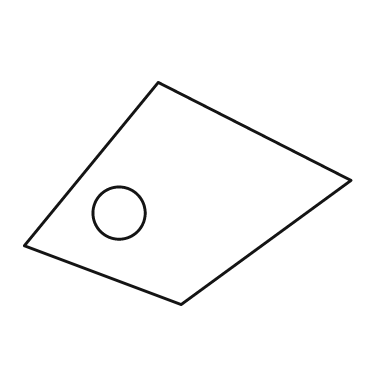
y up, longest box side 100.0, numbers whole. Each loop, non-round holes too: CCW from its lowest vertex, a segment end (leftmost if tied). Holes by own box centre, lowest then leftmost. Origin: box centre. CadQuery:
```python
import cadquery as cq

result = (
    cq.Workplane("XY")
    .moveTo(-2.0, -34.0)
    .lineTo(50.0, 4.0)
    .lineTo(-9.0, 34.0)
    .lineTo(-50.0, -16.0)
    .close()
    .moveTo(-21.0, -6.0)
    .circle(8.0)
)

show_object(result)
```